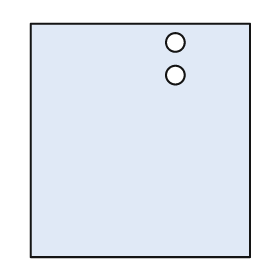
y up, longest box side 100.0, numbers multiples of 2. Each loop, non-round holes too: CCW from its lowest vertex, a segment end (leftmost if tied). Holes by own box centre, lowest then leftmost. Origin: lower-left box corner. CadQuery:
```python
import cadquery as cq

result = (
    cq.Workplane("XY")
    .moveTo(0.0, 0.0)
    .lineTo(94.0, 0.0)
    .lineTo(94.0, 100.0)
    .lineTo(0.0, 100.0)
    .close()
    .moveTo(62.0, 78.0)
    .circle(4.0)
    .moveTo(62.0, 92.0)
    .circle(4.0)
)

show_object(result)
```